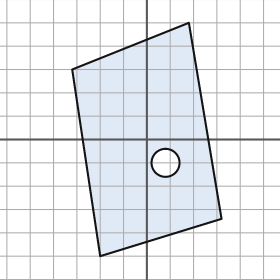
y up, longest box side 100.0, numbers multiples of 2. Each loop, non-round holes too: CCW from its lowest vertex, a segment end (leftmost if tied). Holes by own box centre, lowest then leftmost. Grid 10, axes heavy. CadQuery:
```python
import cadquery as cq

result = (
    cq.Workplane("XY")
    .moveTo(-20.0, -50.0)
    .lineTo(32.0, -34.0)
    .lineTo(18.0, 50.0)
    .lineTo(-32.0, 30.0)
    .close()
    .moveTo(8.0, -10.0)
    .circle(6.0)
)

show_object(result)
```